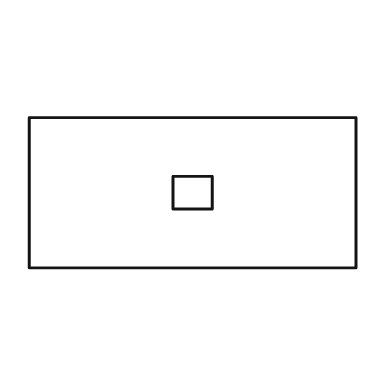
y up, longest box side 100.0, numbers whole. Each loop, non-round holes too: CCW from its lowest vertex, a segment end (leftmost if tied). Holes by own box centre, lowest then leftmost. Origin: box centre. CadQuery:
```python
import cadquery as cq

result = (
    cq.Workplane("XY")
    .moveTo(-50.0, -23.0)
    .lineTo(50.0, -23.0)
    .lineTo(50.0, 23.0)
    .lineTo(-50.0, 23.0)
    .close()
    .moveTo(-6.0, -5.0)
    .lineTo(6.0, -5.0)
    .lineTo(6.0, 5.0)
    .lineTo(-6.0, 5.0)
    .close()
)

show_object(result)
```